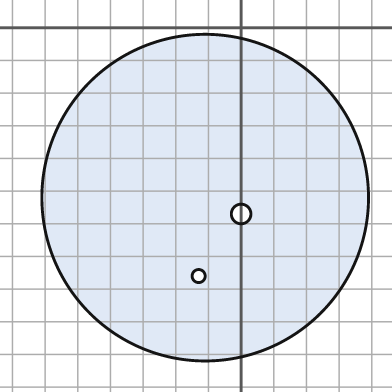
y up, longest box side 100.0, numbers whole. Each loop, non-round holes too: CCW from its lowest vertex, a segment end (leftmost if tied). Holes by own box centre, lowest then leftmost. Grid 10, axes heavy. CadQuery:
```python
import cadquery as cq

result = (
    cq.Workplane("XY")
    .moveTo(-11.0, -52.0)
    .circle(50.0)
    .moveTo(-13.0, -76.0)
    .circle(2.0)
    .moveTo(0.0, -57.0)
    .circle(3.0)
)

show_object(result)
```